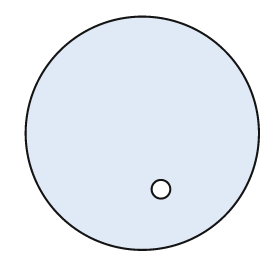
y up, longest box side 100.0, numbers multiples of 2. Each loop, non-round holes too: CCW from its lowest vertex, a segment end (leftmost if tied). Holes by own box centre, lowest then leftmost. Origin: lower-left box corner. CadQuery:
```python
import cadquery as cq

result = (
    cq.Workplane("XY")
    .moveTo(50.0, 50.0)
    .circle(50.0)
    .moveTo(58.0, 26.0)
    .circle(4.0)
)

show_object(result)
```